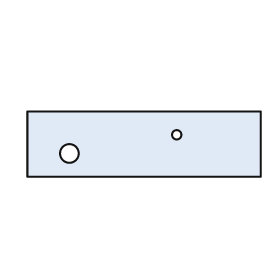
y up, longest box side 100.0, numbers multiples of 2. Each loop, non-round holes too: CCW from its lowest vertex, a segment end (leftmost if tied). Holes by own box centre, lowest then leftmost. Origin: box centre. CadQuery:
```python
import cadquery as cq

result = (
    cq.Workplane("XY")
    .moveTo(-50.0, -14.0)
    .lineTo(50.0, -14.0)
    .lineTo(50.0, 14.0)
    .lineTo(-50.0, 14.0)
    .close()
    .moveTo(-32.0, -4.0)
    .circle(4.0)
    .moveTo(14.0, 4.0)
    .circle(2.0)
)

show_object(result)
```